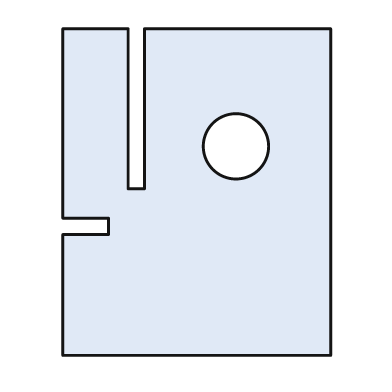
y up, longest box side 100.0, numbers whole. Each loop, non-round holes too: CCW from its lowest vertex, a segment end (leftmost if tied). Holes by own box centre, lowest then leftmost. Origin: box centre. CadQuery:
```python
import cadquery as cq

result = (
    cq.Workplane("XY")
    .moveTo(-41.0, -50.0)
    .lineTo(41.0, -50.0)
    .lineTo(41.0, 50.0)
    .lineTo(-16.0, 50.0)
    .lineTo(-16.0, 1.0)
    .lineTo(-21.0, 1.0)
    .lineTo(-21.0, 50.0)
    .lineTo(-41.0, 50.0)
    .lineTo(-41.0, -8.0)
    .lineTo(-27.0, -8.0)
    .lineTo(-27.0, -13.0)
    .lineTo(-41.0, -13.0)
    .close()
    .moveTo(12.0, 14.0)
    .circle(10.0)
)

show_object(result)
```